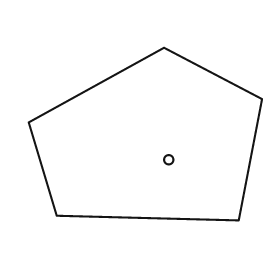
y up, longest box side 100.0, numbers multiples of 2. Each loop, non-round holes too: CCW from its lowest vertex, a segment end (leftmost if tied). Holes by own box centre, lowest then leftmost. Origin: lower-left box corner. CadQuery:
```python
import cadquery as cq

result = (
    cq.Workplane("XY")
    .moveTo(90.0, 0.0)
    .lineTo(100.0, 52.0)
    .lineTo(58.0, 74.0)
    .lineTo(0.0, 42.0)
    .lineTo(12.0, 2.0)
    .close()
    .moveTo(60.0, 26.0)
    .circle(2.0)
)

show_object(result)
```